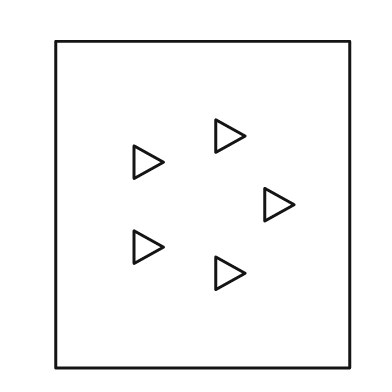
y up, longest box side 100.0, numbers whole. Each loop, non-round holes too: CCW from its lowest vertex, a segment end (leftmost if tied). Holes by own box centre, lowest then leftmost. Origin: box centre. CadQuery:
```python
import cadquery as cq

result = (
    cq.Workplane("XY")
    .moveTo(-45.0, -50.0)
    .lineTo(45.0, -50.0)
    .lineTo(45.0, 50.0)
    .lineTo(-45.0, 50.0)
    .close()
    .moveTo(4.0, -26.0)
    .lineTo(13.0, -21.0)
    .lineTo(4.0, -16.0)
    .close()
    .moveTo(-21.0, -18.0)
    .lineTo(-12.0, -13.0)
    .lineTo(-21.0, -8.0)
    .close()
    .moveTo(19.0, -5.0)
    .lineTo(28.0, 0.0)
    .lineTo(19.0, 5.0)
    .close()
    .moveTo(-21.0, 8.0)
    .lineTo(-12.0, 13.0)
    .lineTo(-21.0, 18.0)
    .close()
    .moveTo(4.0, 16.0)
    .lineTo(13.0, 21.0)
    .lineTo(4.0, 26.0)
    .close()
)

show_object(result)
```